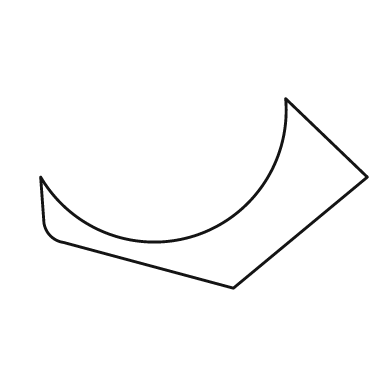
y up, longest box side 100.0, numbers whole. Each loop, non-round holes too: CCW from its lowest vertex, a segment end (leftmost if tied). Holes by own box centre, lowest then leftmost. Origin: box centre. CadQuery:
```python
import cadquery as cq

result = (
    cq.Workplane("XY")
    .moveTo(9.0, -29.0)
    .lineTo(50.0, 5.0)
    .lineTo(25.0, 29.0)
    .threePointArc((-3.0, -13.0), (-50.0, 5.0))
    .lineTo(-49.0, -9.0)
    .threePointArc((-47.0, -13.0), (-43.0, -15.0))
    .close()
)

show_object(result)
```